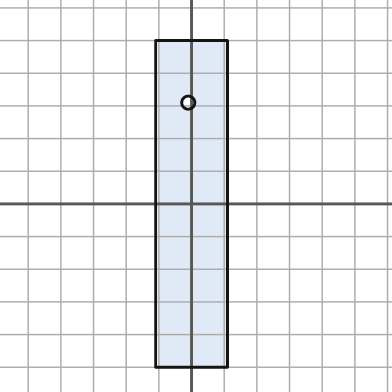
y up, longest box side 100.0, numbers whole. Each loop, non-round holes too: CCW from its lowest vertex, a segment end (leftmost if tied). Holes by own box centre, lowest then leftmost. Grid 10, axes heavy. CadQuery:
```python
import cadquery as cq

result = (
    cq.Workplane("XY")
    .moveTo(-11.0, -50.0)
    .lineTo(11.0, -50.0)
    .lineTo(11.0, 50.0)
    .lineTo(-11.0, 50.0)
    .close()
    .moveTo(-1.0, 31.0)
    .circle(2.0)
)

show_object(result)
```